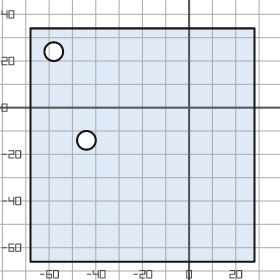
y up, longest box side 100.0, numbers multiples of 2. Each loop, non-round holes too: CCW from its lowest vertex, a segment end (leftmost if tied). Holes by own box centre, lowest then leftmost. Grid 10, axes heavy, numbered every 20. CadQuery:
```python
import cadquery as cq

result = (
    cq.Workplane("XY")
    .moveTo(-68.0, -66.0)
    .lineTo(28.0, -66.0)
    .lineTo(28.0, 34.0)
    .lineTo(-68.0, 34.0)
    .close()
    .moveTo(-44.0, -14.0)
    .circle(4.0)
    .moveTo(-58.0, 24.0)
    .circle(4.0)
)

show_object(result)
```